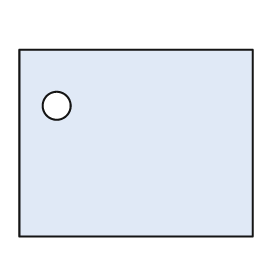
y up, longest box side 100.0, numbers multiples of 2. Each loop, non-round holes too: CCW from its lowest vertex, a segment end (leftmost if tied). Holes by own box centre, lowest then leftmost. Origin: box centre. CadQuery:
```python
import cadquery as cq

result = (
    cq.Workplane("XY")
    .moveTo(-50.0, -40.0)
    .lineTo(50.0, -40.0)
    .lineTo(50.0, 40.0)
    .lineTo(-50.0, 40.0)
    .close()
    .moveTo(-34.0, 16.0)
    .circle(6.0)
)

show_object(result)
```